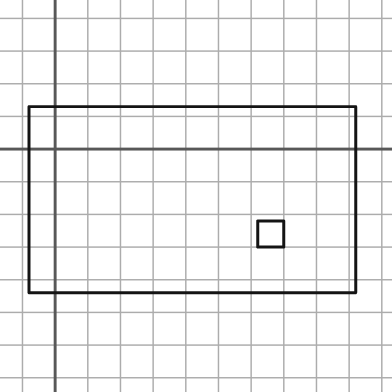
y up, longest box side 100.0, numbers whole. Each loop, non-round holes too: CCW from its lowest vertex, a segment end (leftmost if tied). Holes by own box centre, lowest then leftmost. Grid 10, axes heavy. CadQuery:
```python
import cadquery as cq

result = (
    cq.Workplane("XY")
    .moveTo(-8.0, -44.0)
    .lineTo(92.0, -44.0)
    .lineTo(92.0, 13.0)
    .lineTo(-8.0, 13.0)
    .close()
    .moveTo(62.0, -30.0)
    .lineTo(70.0, -30.0)
    .lineTo(70.0, -22.0)
    .lineTo(62.0, -22.0)
    .close()
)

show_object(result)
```